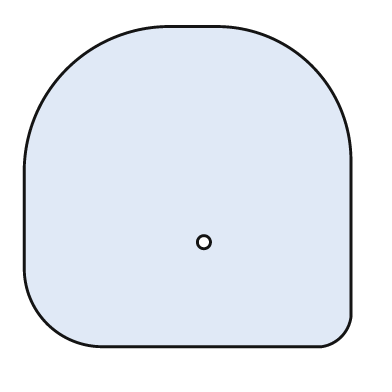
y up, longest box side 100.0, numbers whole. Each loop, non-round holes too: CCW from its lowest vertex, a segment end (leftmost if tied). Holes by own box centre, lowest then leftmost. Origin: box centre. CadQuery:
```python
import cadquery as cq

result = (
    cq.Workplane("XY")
    .moveTo(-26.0, -49.0)
    .lineTo(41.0, -49.0)
    .threePointArc((47.0, -46.0), (50.0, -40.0))
    .lineTo(50.0, 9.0)
    .threePointArc((38.0, 37.0), (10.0, 49.0))
    .lineTo(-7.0, 49.0)
    .threePointArc((-37.0, 36.0), (-50.0, 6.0))
    .lineTo(-50.0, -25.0)
    .threePointArc((-43.0, -42.0), (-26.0, -49.0))
    .close()
    .moveTo(5.0, -17.0)
    .circle(2.0)
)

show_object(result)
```